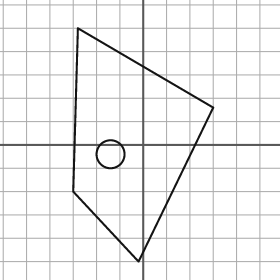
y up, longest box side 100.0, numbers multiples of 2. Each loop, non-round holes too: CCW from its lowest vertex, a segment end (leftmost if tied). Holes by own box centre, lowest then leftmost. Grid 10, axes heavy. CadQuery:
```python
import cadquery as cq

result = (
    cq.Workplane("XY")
    .moveTo(-2.0, -50.0)
    .lineTo(30.0, 16.0)
    .lineTo(-28.0, 50.0)
    .lineTo(-30.0, -20.0)
    .close()
    .moveTo(-14.0, -4.0)
    .circle(6.0)
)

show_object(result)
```